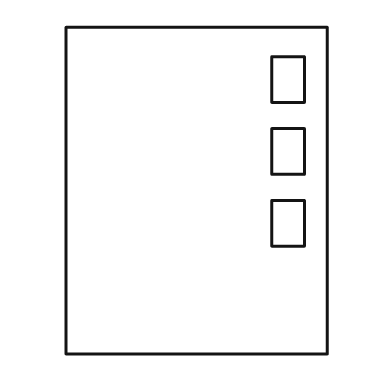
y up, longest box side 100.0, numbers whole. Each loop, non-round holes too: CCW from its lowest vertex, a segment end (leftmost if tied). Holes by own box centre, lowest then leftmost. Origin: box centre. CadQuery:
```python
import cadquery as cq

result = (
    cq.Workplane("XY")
    .moveTo(-40.0, -50.0)
    .lineTo(40.0, -50.0)
    .lineTo(40.0, 50.0)
    .lineTo(-40.0, 50.0)
    .close()
    .moveTo(23.0, -17.0)
    .lineTo(33.0, -17.0)
    .lineTo(33.0, -3.0)
    .lineTo(23.0, -3.0)
    .close()
    .moveTo(23.0, 5.0)
    .lineTo(33.0, 5.0)
    .lineTo(33.0, 19.0)
    .lineTo(23.0, 19.0)
    .close()
    .moveTo(23.0, 27.0)
    .lineTo(33.0, 27.0)
    .lineTo(33.0, 41.0)
    .lineTo(23.0, 41.0)
    .close()
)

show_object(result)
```